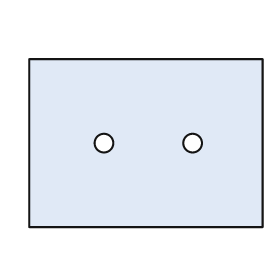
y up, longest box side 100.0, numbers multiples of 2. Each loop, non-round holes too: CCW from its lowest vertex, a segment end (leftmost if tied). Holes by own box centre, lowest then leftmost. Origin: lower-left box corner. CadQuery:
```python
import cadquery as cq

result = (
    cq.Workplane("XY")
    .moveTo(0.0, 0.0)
    .lineTo(100.0, 0.0)
    .lineTo(100.0, 72.0)
    .lineTo(0.0, 72.0)
    .close()
    .moveTo(32.0, 36.0)
    .circle(4.0)
    .moveTo(70.0, 36.0)
    .circle(4.0)
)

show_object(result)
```